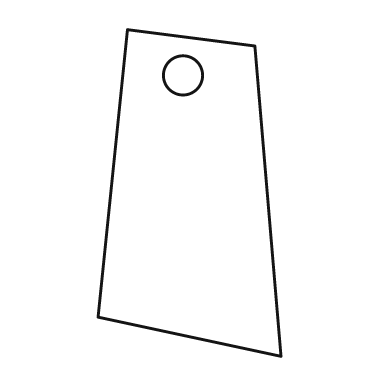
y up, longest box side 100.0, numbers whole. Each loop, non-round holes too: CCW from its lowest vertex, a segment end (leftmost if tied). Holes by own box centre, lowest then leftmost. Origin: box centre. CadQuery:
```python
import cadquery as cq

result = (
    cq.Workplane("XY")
    .moveTo(28.0, -50.0)
    .lineTo(20.0, 45.0)
    .lineTo(-19.0, 50.0)
    .lineTo(-28.0, -38.0)
    .close()
    .moveTo(-2.0, 36.0)
    .circle(6.0)
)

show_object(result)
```